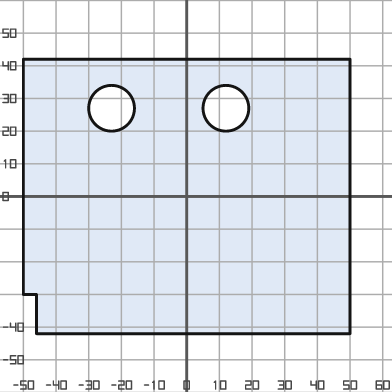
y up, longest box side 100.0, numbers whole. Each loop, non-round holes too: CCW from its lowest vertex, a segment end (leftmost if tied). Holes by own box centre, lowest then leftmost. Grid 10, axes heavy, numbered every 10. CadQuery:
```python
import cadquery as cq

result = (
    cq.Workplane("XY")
    .moveTo(-46.0, -42.0)
    .lineTo(50.0, -42.0)
    .lineTo(50.0, 42.0)
    .lineTo(-50.0, 42.0)
    .lineTo(-50.0, -30.0)
    .lineTo(-46.0, -30.0)
    .close()
    .moveTo(-23.0, 27.0)
    .circle(7.0)
    .moveTo(12.0, 27.0)
    .circle(7.0)
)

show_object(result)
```